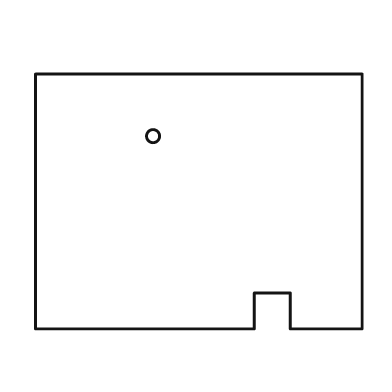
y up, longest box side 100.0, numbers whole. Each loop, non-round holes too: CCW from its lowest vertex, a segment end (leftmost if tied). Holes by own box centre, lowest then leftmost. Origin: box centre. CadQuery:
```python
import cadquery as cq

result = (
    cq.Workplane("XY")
    .moveTo(-50.0, -39.0)
    .lineTo(17.0, -39.0)
    .lineTo(17.0, -28.0)
    .lineTo(28.0, -28.0)
    .lineTo(28.0, -39.0)
    .lineTo(50.0, -39.0)
    .lineTo(50.0, 39.0)
    .lineTo(-50.0, 39.0)
    .close()
    .moveTo(-14.0, 20.0)
    .circle(2.0)
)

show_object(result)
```